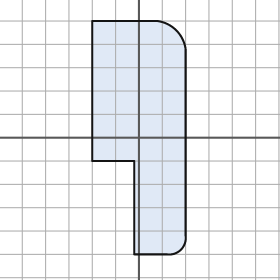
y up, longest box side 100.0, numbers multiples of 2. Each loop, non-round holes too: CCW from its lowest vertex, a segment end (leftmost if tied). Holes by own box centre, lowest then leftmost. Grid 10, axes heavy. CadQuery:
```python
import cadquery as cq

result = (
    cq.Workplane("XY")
    .moveTo(-2.0, -50.0)
    .lineTo(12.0, -50.0)
    .threePointArc((18.0, -48.0), (20.0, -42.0))
    .lineTo(20.0, 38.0)
    .threePointArc((16.0, 46.0), (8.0, 50.0))
    .lineTo(-20.0, 50.0)
    .lineTo(-20.0, -10.0)
    .lineTo(-2.0, -10.0)
    .close()
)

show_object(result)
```